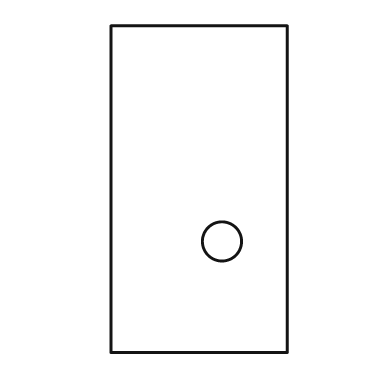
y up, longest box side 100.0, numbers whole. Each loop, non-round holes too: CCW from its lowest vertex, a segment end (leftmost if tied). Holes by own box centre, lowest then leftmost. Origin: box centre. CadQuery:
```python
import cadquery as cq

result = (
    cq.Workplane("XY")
    .moveTo(-27.0, -50.0)
    .lineTo(27.0, -50.0)
    .lineTo(27.0, 50.0)
    .lineTo(-27.0, 50.0)
    .close()
    .moveTo(7.0, -16.0)
    .circle(6.0)
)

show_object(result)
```